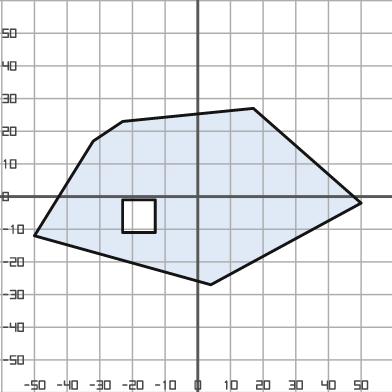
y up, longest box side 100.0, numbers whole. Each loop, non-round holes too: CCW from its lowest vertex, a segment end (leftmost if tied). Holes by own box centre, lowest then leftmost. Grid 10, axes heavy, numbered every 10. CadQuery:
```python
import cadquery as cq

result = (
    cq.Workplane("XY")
    .moveTo(4.0, -27.0)
    .lineTo(50.0, -2.0)
    .lineTo(17.0, 27.0)
    .lineTo(-23.0, 23.0)
    .lineTo(-32.0, 17.0)
    .lineTo(-50.0, -12.0)
    .close()
    .moveTo(-23.0, -11.0)
    .lineTo(-13.0, -11.0)
    .lineTo(-13.0, -1.0)
    .lineTo(-23.0, -1.0)
    .close()
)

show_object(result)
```